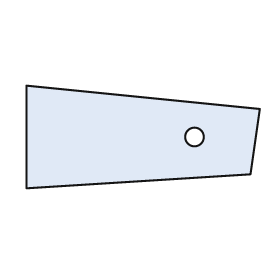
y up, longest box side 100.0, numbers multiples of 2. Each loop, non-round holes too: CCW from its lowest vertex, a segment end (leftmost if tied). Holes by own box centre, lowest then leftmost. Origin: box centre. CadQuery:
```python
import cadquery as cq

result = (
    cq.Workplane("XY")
    .moveTo(-50.0, -22.0)
    .lineTo(46.0, -16.0)
    .lineTo(50.0, 12.0)
    .lineTo(-50.0, 22.0)
    .close()
    .moveTo(22.0, 0.0)
    .circle(4.0)
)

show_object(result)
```